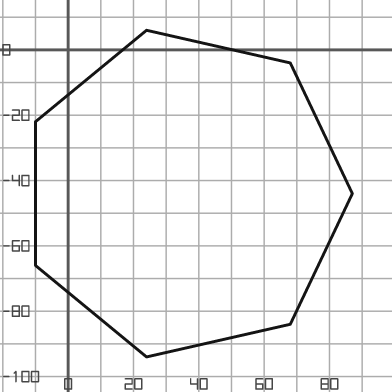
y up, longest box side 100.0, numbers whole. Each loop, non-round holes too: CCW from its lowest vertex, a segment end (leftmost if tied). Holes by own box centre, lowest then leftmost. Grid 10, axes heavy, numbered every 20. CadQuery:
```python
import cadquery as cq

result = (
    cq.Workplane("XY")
    .moveTo(24.0, -94.0)
    .lineTo(68.0, -84.0)
    .lineTo(87.0, -44.0)
    .lineTo(68.0, -4.0)
    .lineTo(24.0, 6.0)
    .lineTo(-10.0, -22.0)
    .lineTo(-10.0, -66.0)
    .close()
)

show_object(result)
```